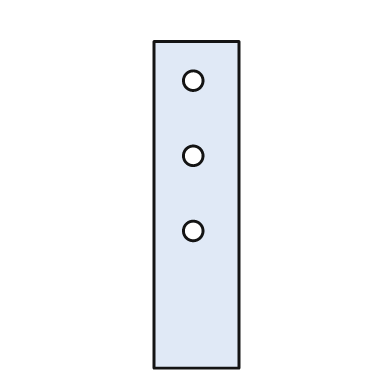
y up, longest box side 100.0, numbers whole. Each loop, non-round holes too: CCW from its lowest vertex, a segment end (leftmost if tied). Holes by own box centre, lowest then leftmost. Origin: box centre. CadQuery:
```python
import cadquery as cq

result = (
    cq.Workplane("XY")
    .moveTo(-13.0, -50.0)
    .lineTo(13.0, -50.0)
    .lineTo(13.0, 50.0)
    .lineTo(-13.0, 50.0)
    .close()
    .moveTo(-1.0, -8.0)
    .circle(3.0)
    .moveTo(-1.0, 15.0)
    .circle(3.0)
    .moveTo(-1.0, 38.0)
    .circle(3.0)
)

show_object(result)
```